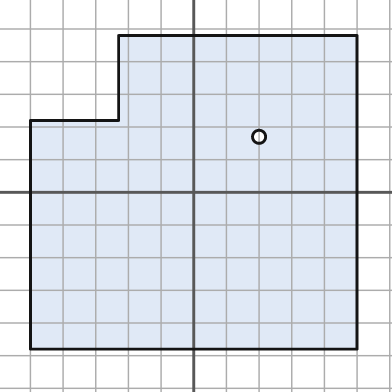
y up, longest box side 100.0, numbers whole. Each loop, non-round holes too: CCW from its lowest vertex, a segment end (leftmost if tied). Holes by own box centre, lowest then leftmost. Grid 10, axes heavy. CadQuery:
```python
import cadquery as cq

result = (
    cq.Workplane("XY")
    .moveTo(-50.0, -48.0)
    .lineTo(50.0, -48.0)
    .lineTo(50.0, 48.0)
    .lineTo(-23.0, 48.0)
    .lineTo(-23.0, 22.0)
    .lineTo(-50.0, 22.0)
    .close()
    .moveTo(20.0, 17.0)
    .circle(2.0)
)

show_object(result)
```